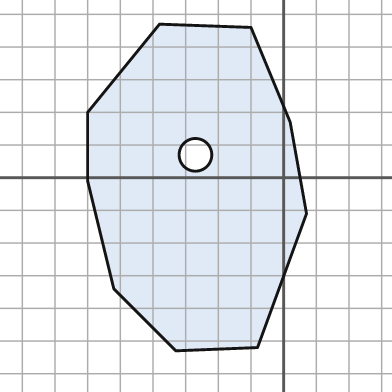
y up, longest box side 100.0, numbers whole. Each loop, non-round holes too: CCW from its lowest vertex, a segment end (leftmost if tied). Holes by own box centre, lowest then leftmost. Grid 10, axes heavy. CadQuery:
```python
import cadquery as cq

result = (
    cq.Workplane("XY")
    .moveTo(-33.0, -53.0)
    .lineTo(-8.0, -52.0)
    .lineTo(7.0, -11.0)
    .lineTo(2.0, 17.0)
    .lineTo(-10.0, 46.0)
    .lineTo(-38.0, 47.0)
    .lineTo(-60.0, 20.0)
    .lineTo(-60.0, -1.0)
    .lineTo(-52.0, -34.0)
    .close()
    .moveTo(-27.0, 7.0)
    .circle(5.0)
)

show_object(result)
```